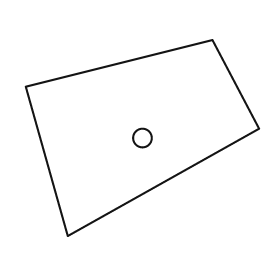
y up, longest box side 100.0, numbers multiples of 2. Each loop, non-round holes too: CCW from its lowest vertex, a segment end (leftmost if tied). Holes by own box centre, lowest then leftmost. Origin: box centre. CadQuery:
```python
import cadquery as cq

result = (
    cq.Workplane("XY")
    .moveTo(-32.0, -42.0)
    .lineTo(50.0, 4.0)
    .lineTo(30.0, 42.0)
    .lineTo(-50.0, 22.0)
    .close()
    .moveTo(0.0, 0.0)
    .circle(4.0)
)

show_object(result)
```